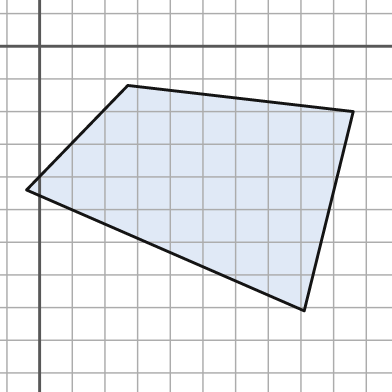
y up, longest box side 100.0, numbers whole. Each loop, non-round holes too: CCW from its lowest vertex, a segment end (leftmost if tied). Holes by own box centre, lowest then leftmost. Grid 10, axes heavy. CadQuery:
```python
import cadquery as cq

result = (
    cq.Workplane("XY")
    .moveTo(81.0, -81.0)
    .lineTo(96.0, -20.0)
    .lineTo(27.0, -12.0)
    .lineTo(-4.0, -44.0)
    .close()
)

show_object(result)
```